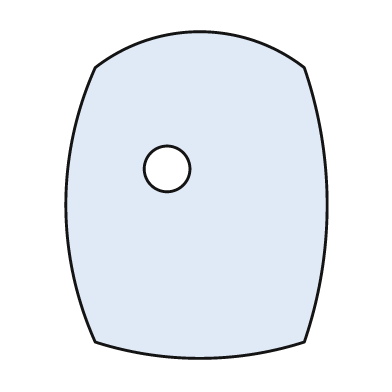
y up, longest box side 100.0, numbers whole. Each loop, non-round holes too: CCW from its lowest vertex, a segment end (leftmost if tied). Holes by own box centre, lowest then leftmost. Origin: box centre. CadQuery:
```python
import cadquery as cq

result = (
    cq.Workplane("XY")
    .moveTo(-31.0, -45.0)
    .threePointArc((1.0, -50.0), (33.0, -45.0))
    .threePointArc((40.0, -3.0), (33.0, 39.0))
    .threePointArc((1.0, 50.0), (-31.0, 39.0))
    .threePointArc((-40.0, -3.0), (-31.0, -45.0))
    .close()
    .moveTo(-9.0, 8.0)
    .circle(7.0)
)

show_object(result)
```